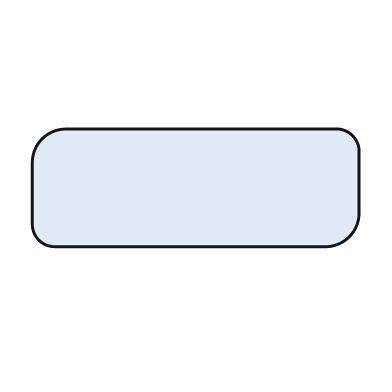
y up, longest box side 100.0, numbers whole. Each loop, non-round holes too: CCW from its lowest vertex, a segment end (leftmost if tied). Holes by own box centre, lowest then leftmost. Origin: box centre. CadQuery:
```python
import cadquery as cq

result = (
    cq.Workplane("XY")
    .moveTo(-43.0, -18.0)
    .lineTo(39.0, -18.0)
    .threePointArc((47.0, -15.0), (50.0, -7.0))
    .lineTo(50.0, 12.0)
    .threePointArc((48.0, 16.0), (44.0, 18.0))
    .lineTo(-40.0, 18.0)
    .threePointArc((-47.0, 15.0), (-50.0, 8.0))
    .lineTo(-50.0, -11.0)
    .threePointArc((-48.0, -16.0), (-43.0, -18.0))
    .close()
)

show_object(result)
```